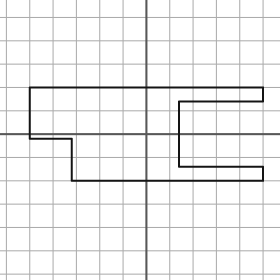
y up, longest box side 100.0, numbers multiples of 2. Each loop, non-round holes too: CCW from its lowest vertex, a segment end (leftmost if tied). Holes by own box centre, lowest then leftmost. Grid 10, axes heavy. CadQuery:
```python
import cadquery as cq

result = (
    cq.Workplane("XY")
    .moveTo(-32.0, -20.0)
    .lineTo(50.0, -20.0)
    .lineTo(50.0, -14.0)
    .lineTo(14.0, -14.0)
    .lineTo(14.0, 14.0)
    .lineTo(50.0, 14.0)
    .lineTo(50.0, 20.0)
    .lineTo(-50.0, 20.0)
    .lineTo(-50.0, -2.0)
    .lineTo(-32.0, -2.0)
    .close()
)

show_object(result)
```